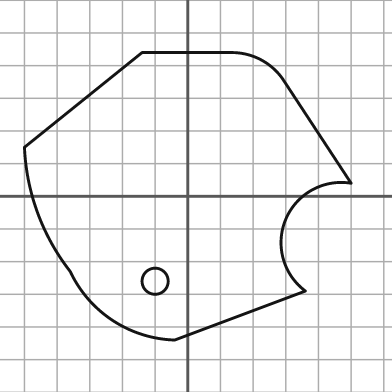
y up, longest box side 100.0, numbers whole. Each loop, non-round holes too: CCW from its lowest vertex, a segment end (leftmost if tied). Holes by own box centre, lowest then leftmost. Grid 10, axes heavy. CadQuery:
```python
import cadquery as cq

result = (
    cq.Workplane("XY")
    .moveTo(-4.0, -44.0)
    .lineTo(36.0, -29.0)
    .threePointArc((30.0, -7.0), (50.0, 4.0))
    .lineTo(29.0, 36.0)
    .threePointArc((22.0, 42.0), (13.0, 44.0))
    .lineTo(-14.0, 44.0)
    .lineTo(-50.0, 15.0)
    .threePointArc((-46.0, -5.0), (-36.0, -23.0))
    .threePointArc((-23.0, -38.0), (-4.0, -44.0))
    .close()
    .moveTo(-10.0, -26.0)
    .circle(4.0)
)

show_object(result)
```